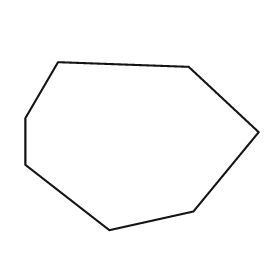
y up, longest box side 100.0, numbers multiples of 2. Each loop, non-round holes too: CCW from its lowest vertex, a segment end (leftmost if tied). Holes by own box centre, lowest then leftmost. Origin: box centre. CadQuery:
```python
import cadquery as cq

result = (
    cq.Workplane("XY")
    .moveTo(-14.0, -36.0)
    .lineTo(22.0, -28.0)
    .lineTo(50.0, 6.0)
    .lineTo(20.0, 34.0)
    .lineTo(-36.0, 36.0)
    .lineTo(-50.0, 12.0)
    .lineTo(-50.0, -8.0)
    .close()
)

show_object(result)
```